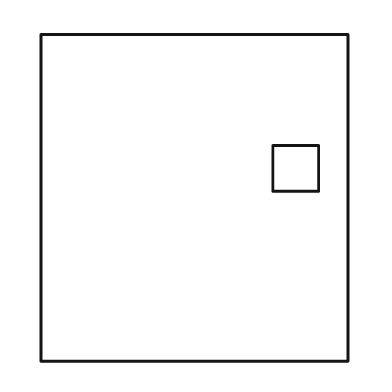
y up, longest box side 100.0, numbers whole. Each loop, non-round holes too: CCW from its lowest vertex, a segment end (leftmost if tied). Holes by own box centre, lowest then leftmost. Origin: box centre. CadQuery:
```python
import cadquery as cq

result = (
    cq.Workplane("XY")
    .moveTo(-47.0, -50.0)
    .lineTo(47.0, -50.0)
    .lineTo(47.0, 50.0)
    .lineTo(-47.0, 50.0)
    .close()
    .moveTo(24.0, 2.0)
    .lineTo(38.0, 2.0)
    .lineTo(38.0, 16.0)
    .lineTo(24.0, 16.0)
    .close()
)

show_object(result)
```